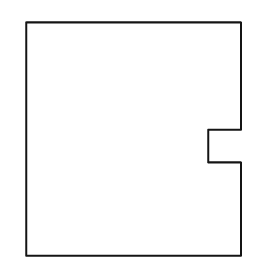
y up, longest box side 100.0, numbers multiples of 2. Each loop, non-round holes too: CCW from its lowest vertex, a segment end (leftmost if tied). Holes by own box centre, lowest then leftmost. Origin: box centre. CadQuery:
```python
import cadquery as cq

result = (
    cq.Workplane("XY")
    .moveTo(-46.0, -50.0)
    .lineTo(46.0, -50.0)
    .lineTo(46.0, -10.0)
    .lineTo(32.0, -10.0)
    .lineTo(32.0, 4.0)
    .lineTo(46.0, 4.0)
    .lineTo(46.0, 50.0)
    .lineTo(-46.0, 50.0)
    .close()
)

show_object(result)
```